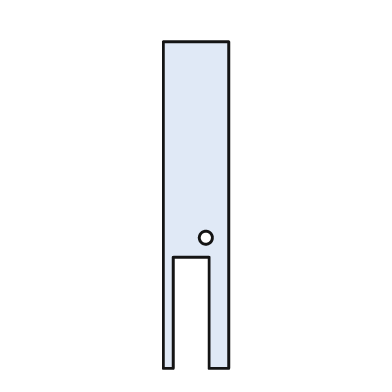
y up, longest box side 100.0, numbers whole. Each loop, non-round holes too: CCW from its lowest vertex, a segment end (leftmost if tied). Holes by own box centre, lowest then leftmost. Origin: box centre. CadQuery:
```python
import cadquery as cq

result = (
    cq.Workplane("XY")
    .moveTo(-10.0, -50.0)
    .lineTo(-7.0, -50.0)
    .lineTo(-7.0, -16.0)
    .lineTo(4.0, -16.0)
    .lineTo(4.0, -50.0)
    .lineTo(10.0, -50.0)
    .lineTo(10.0, 50.0)
    .lineTo(-10.0, 50.0)
    .close()
    .moveTo(3.0, -10.0)
    .circle(2.0)
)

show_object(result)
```